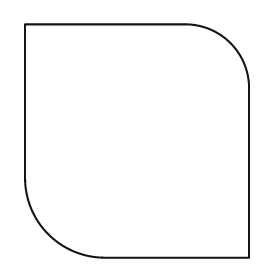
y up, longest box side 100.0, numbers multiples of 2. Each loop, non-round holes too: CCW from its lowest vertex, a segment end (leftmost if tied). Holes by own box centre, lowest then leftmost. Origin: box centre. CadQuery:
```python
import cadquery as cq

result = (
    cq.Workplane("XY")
    .moveTo(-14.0, -50.0)
    .lineTo(48.0, -50.0)
    .lineTo(48.0, 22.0)
    .threePointArc((40.0, 42.0), (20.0, 50.0))
    .lineTo(-48.0, 50.0)
    .lineTo(-48.0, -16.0)
    .threePointArc((-38.0, -40.0), (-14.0, -50.0))
    .close()
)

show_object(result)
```